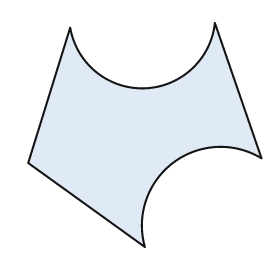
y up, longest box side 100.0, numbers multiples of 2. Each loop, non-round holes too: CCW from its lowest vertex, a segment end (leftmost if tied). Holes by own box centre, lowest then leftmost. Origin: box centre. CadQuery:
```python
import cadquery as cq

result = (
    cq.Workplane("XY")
    .moveTo(0.0, -48.0)
    .threePointArc((12.0, -12.0), (50.0, -10.0))
    .lineTo(30.0, 48.0)
    .threePointArc((0.0, 20.0), (-32.0, 46.0))
    .lineTo(-50.0, -12.0)
    .close()
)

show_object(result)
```